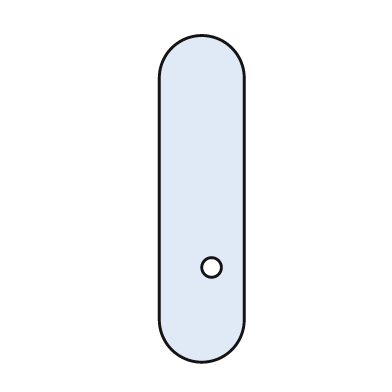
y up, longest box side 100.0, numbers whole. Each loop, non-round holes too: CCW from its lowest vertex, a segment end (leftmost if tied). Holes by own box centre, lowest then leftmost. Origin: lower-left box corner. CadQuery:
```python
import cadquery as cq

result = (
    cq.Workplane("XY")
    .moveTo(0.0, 13.0)
    .threePointArc((13.0, 0.0), (26.0, 13.0))
    .lineTo(26.0, 87.0)
    .threePointArc((13.0, 100.0), (0.0, 87.0))
    .close()
    .moveTo(16.0, 29.0)
    .circle(3.0)
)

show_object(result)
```